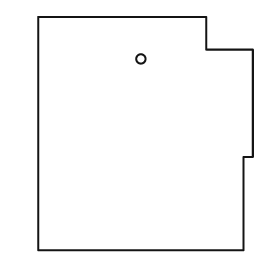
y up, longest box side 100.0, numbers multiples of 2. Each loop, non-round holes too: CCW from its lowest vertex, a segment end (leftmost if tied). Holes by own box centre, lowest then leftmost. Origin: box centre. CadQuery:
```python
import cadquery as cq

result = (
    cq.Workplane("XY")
    .moveTo(-46.0, -50.0)
    .lineTo(42.0, -50.0)
    .lineTo(42.0, -10.0)
    .lineTo(46.0, -10.0)
    .lineTo(46.0, 36.0)
    .lineTo(26.0, 36.0)
    .lineTo(26.0, 50.0)
    .lineTo(-46.0, 50.0)
    .close()
    .moveTo(-2.0, 32.0)
    .circle(2.0)
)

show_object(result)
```